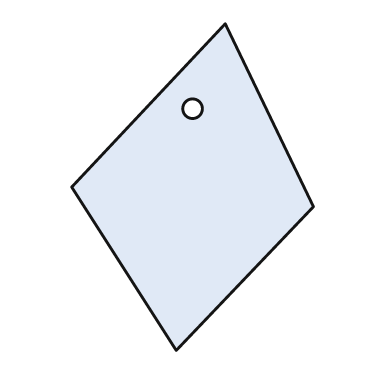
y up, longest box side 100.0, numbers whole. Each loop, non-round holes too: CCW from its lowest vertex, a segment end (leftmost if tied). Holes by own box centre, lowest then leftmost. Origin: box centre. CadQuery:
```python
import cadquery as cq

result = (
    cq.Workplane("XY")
    .moveTo(-5.0, -50.0)
    .lineTo(37.0, -6.0)
    .lineTo(10.0, 50.0)
    .lineTo(-37.0, 0.0)
    .close()
    .moveTo(0.0, 24.0)
    .circle(3.0)
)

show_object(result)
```